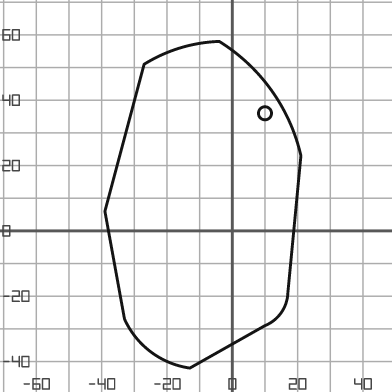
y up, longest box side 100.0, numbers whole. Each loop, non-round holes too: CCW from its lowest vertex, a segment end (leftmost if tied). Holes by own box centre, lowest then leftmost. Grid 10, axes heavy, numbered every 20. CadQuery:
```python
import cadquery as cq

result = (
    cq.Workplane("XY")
    .moveTo(-13.0, -42.0)
    .lineTo(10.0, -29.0)
    .threePointArc((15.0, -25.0), (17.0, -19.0))
    .lineTo(21.0, 23.0)
    .threePointArc((12.0, 43.0), (-4.0, 58.0))
    .threePointArc((-16.0, 56.0), (-27.0, 51.0))
    .lineTo(-39.0, 6.0)
    .lineTo(-33.0, -27.0)
    .threePointArc((-25.0, -37.0), (-13.0, -42.0))
    .close()
    .moveTo(10.0, 36.0)
    .circle(2.0)
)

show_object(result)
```